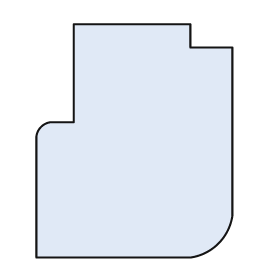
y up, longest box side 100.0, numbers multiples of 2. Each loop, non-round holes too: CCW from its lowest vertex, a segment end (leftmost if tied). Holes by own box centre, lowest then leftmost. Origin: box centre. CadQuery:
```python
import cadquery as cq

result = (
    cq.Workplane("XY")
    .moveTo(-42.0, -50.0)
    .lineTo(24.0, -50.0)
    .threePointArc((36.0, -44.0), (42.0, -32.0))
    .lineTo(42.0, 40.0)
    .lineTo(24.0, 40.0)
    .lineTo(24.0, 50.0)
    .lineTo(-26.0, 50.0)
    .lineTo(-26.0, 8.0)
    .lineTo(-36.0, 8.0)
    .threePointArc((-40.0, 6.0), (-42.0, 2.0))
    .close()
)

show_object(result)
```